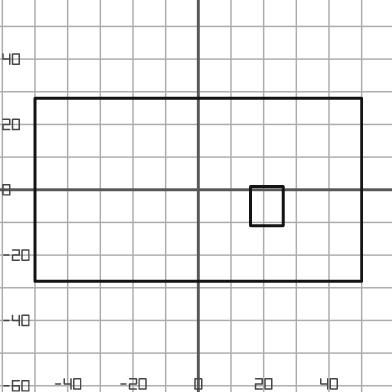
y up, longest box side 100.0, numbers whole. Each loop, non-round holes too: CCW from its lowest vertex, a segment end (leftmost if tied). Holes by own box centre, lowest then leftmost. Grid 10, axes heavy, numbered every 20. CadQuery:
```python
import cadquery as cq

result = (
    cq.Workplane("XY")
    .moveTo(-50.0, -28.0)
    .lineTo(50.0, -28.0)
    .lineTo(50.0, 28.0)
    .lineTo(-50.0, 28.0)
    .close()
    .moveTo(16.0, -11.0)
    .lineTo(26.0, -11.0)
    .lineTo(26.0, 1.0)
    .lineTo(16.0, 1.0)
    .close()
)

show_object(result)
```